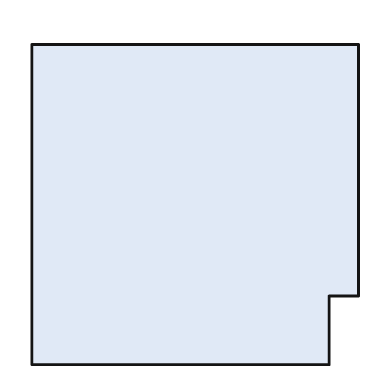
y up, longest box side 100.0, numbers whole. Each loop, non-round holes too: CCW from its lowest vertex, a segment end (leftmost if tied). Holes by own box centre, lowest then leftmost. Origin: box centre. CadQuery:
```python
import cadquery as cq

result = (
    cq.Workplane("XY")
    .moveTo(-50.0, -49.0)
    .lineTo(41.0, -49.0)
    .lineTo(41.0, -28.0)
    .lineTo(50.0, -28.0)
    .lineTo(50.0, 49.0)
    .lineTo(-50.0, 49.0)
    .close()
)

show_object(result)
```